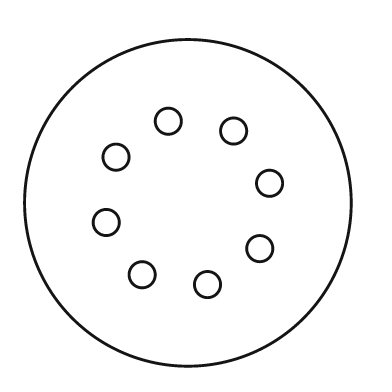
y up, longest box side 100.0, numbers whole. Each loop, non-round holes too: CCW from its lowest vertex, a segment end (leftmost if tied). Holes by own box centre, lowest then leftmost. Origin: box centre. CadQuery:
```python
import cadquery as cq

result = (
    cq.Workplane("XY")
    .moveTo(0.0, 0.0)
    .circle(50.0)
    .moveTo(6.0, -25.0)
    .circle(4.0)
    .moveTo(-14.0, -22.0)
    .circle(4.0)
    .moveTo(22.0, -14.0)
    .circle(4.0)
    .moveTo(-25.0, -6.0)
    .circle(4.0)
    .moveTo(25.0, 6.0)
    .circle(4.0)
    .moveTo(-22.0, 14.0)
    .circle(4.0)
    .moveTo(14.0, 22.0)
    .circle(4.0)
    .moveTo(-6.0, 25.0)
    .circle(4.0)
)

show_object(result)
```